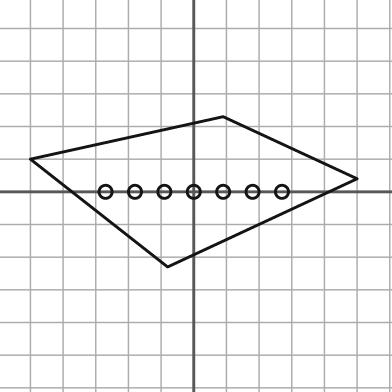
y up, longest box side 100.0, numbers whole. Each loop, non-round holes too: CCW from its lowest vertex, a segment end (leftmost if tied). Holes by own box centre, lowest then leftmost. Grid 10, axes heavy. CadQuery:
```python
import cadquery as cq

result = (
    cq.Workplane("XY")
    .moveTo(-8.0, -23.0)
    .lineTo(50.0, 4.0)
    .lineTo(9.0, 23.0)
    .lineTo(-50.0, 10.0)
    .close()
    .moveTo(-27.0, 0.0)
    .circle(2.0)
    .moveTo(-18.0, 0.0)
    .circle(2.0)
    .moveTo(-9.0, 0.0)
    .circle(2.0)
    .moveTo(0.0, 0.0)
    .circle(2.0)
    .moveTo(9.0, 0.0)
    .circle(2.0)
    .moveTo(18.0, 0.0)
    .circle(2.0)
    .moveTo(27.0, 0.0)
    .circle(2.0)
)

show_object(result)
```